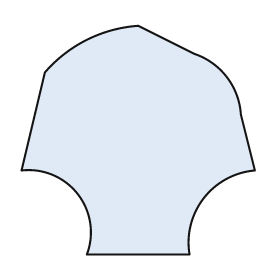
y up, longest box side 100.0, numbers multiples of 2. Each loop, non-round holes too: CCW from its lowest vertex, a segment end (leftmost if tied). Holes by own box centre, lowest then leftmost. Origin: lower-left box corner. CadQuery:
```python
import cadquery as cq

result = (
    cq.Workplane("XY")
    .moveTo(28.0, 0.0)
    .lineTo(72.0, 0.0)
    .threePointArc((78.0, 24.0), (100.0, 36.0))
    .lineTo(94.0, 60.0)
    .threePointArc((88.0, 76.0), (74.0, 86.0))
    .lineTo(50.0, 98.0)
    .threePointArc((28.0, 92.0), (10.0, 78.0))
    .lineTo(0.0, 36.0)
    .threePointArc((24.0, 26.0), (28.0, 0.0))
    .close()
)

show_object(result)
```